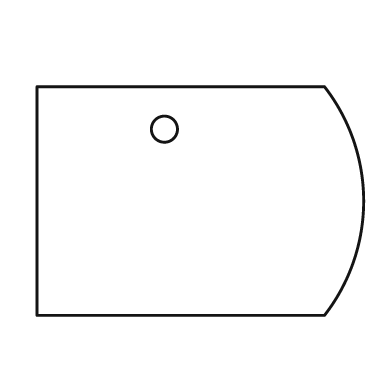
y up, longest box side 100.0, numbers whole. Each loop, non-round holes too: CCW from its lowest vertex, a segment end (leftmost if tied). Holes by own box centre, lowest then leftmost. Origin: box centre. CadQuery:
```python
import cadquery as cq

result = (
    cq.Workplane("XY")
    .moveTo(-50.0, -35.0)
    .lineTo(38.0, -35.0)
    .threePointArc((50.0, 0.0), (38.0, 35.0))
    .lineTo(-50.0, 35.0)
    .close()
    .moveTo(-11.0, 22.0)
    .circle(4.0)
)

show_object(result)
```